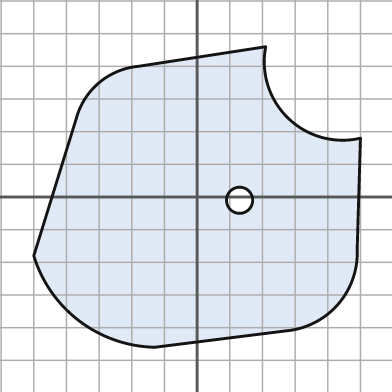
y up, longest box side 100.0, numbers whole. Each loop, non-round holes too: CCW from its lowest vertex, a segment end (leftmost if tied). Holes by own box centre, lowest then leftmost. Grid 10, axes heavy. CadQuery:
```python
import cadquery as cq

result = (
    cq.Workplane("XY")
    .moveTo(-13.0, -46.0)
    .lineTo(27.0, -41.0)
    .threePointArc((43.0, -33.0), (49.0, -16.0))
    .lineTo(50.0, 18.0)
    .threePointArc((28.0, 24.0), (21.0, 46.0))
    .lineTo(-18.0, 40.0)
    .threePointArc((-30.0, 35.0), (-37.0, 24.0))
    .lineTo(-50.0, -18.0)
    .threePointArc((-36.0, -38.0), (-13.0, -46.0))
    .close()
    .moveTo(13.0, -1.0)
    .circle(4.0)
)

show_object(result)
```